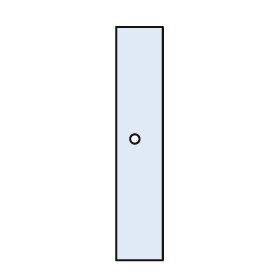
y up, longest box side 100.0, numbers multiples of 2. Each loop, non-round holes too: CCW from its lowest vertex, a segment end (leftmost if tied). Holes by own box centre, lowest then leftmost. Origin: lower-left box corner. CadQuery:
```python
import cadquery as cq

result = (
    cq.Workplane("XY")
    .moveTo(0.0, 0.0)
    .lineTo(20.0, 0.0)
    .lineTo(20.0, 100.0)
    .lineTo(0.0, 100.0)
    .close()
    .moveTo(8.0, 52.0)
    .circle(2.0)
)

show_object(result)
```